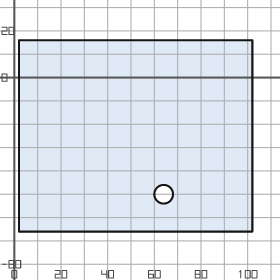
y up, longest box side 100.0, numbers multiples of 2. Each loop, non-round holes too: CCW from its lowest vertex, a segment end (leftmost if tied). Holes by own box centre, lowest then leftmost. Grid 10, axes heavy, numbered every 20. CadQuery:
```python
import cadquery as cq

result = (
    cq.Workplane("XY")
    .moveTo(2.0, -66.0)
    .lineTo(102.0, -66.0)
    .lineTo(102.0, 16.0)
    .lineTo(2.0, 16.0)
    .close()
    .moveTo(64.0, -50.0)
    .circle(4.0)
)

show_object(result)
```